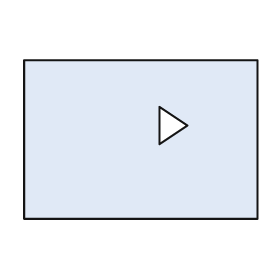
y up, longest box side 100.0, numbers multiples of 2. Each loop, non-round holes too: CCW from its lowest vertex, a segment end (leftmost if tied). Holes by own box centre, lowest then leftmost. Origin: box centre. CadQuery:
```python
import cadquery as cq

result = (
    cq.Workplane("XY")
    .moveTo(-50.0, -34.0)
    .lineTo(50.0, -34.0)
    .lineTo(50.0, 34.0)
    .lineTo(-50.0, 34.0)
    .close()
    .moveTo(8.0, -2.0)
    .lineTo(20.0, 6.0)
    .lineTo(8.0, 14.0)
    .close()
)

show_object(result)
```